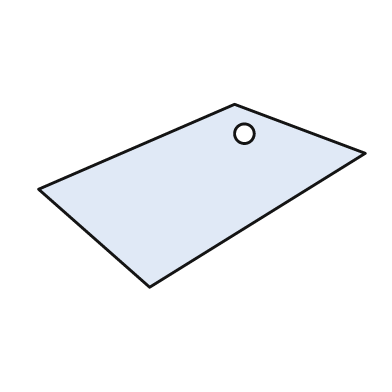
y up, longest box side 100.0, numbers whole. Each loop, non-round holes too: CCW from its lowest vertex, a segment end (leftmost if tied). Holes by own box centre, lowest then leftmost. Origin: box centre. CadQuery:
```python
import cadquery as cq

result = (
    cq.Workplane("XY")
    .moveTo(-16.0, -28.0)
    .lineTo(50.0, 13.0)
    .lineTo(10.0, 28.0)
    .lineTo(-50.0, 2.0)
    .close()
    .moveTo(13.0, 19.0)
    .circle(3.0)
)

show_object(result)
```